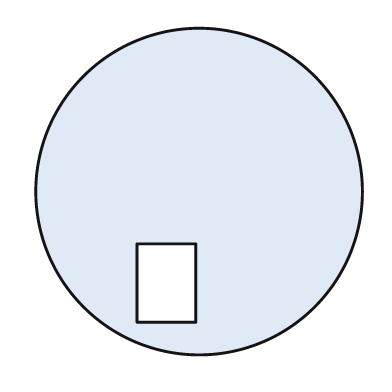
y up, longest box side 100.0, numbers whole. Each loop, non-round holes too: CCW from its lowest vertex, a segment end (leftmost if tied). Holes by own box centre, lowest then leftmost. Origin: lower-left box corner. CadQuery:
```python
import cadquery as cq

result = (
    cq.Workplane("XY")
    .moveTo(50.0, 50.0)
    .circle(50.0)
    .moveTo(31.0, 10.0)
    .lineTo(49.0, 10.0)
    .lineTo(49.0, 34.0)
    .lineTo(31.0, 34.0)
    .close()
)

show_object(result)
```